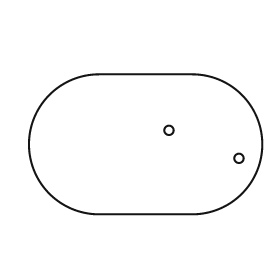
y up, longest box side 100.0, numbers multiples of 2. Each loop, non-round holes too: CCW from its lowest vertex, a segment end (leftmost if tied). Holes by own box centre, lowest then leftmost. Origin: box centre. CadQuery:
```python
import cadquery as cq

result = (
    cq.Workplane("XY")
    .moveTo(-20.0, -30.0)
    .lineTo(20.0, -30.0)
    .threePointArc((50.0, 0.0), (20.0, 30.0))
    .lineTo(-20.0, 30.0)
    .threePointArc((-50.0, 0.0), (-20.0, -30.0))
    .close()
    .moveTo(40.0, -6.0)
    .circle(2.0)
    .moveTo(10.0, 6.0)
    .circle(2.0)
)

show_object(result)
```